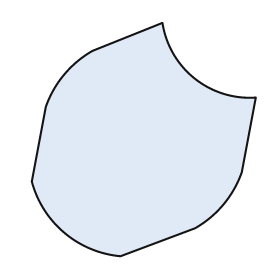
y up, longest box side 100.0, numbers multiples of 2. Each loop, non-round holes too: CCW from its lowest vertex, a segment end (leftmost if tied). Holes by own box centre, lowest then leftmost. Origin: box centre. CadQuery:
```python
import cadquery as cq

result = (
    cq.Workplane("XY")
    .moveTo(-10.0, -50.0)
    .lineTo(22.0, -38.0)
    .threePointArc((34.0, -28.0), (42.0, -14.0))
    .lineTo(48.0, 18.0)
    .threePointArc((22.0, 26.0), (8.0, 50.0))
    .lineTo(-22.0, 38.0)
    .threePointArc((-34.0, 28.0), (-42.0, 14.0))
    .lineTo(-48.0, -18.0)
    .threePointArc((-34.0, -40.0), (-10.0, -50.0))
    .close()
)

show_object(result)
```